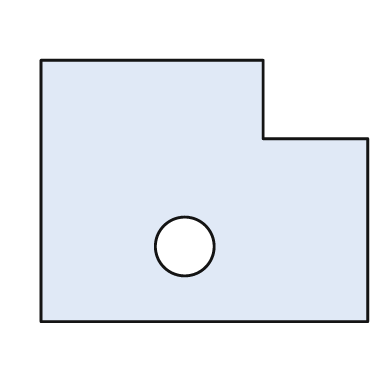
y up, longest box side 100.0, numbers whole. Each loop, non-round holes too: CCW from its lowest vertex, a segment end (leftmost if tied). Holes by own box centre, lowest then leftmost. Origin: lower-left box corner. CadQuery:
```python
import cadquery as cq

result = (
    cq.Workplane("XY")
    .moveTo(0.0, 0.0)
    .lineTo(100.0, 0.0)
    .lineTo(100.0, 56.0)
    .lineTo(68.0, 56.0)
    .lineTo(68.0, 80.0)
    .lineTo(0.0, 80.0)
    .close()
    .moveTo(44.0, 23.0)
    .circle(9.0)
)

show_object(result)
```